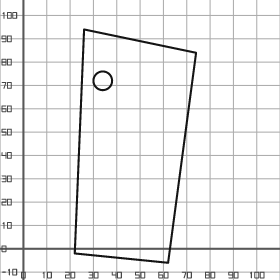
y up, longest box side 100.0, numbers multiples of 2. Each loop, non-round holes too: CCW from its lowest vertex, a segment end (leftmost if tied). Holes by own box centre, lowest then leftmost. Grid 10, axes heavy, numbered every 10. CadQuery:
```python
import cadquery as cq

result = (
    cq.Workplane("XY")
    .moveTo(62.0, -6.0)
    .lineTo(74.0, 84.0)
    .lineTo(26.0, 94.0)
    .lineTo(22.0, -2.0)
    .close()
    .moveTo(34.0, 72.0)
    .circle(4.0)
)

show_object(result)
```